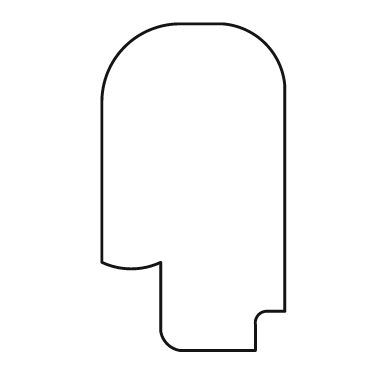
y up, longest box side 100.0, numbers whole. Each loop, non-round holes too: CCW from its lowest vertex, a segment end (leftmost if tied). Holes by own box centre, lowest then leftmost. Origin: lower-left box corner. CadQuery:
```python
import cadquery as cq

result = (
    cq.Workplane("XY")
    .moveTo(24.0, 0.0)
    .lineTo(47.0, 0.0)
    .lineTo(47.0, 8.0)
    .threePointArc((48.0, 11.0), (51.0, 12.0))
    .lineTo(56.0, 12.0)
    .lineTo(56.0, 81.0)
    .threePointArc((50.0, 94.0), (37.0, 100.0))
    .lineTo(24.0, 100.0)
    .threePointArc((7.0, 93.0), (0.0, 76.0))
    .lineTo(0.0, 27.0)
    .threePointArc((9.0, 25.0), (18.0, 27.0))
    .lineTo(18.0, 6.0)
    .threePointArc((20.0, 2.0), (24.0, 0.0))
    .close()
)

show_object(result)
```